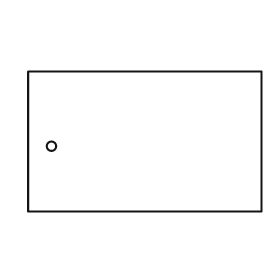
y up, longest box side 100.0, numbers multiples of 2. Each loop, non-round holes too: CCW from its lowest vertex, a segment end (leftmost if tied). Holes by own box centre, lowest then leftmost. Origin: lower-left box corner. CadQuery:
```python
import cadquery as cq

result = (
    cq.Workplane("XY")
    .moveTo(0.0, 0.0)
    .lineTo(100.0, 0.0)
    .lineTo(100.0, 60.0)
    .lineTo(0.0, 60.0)
    .close()
    .moveTo(10.0, 28.0)
    .circle(2.0)
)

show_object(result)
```